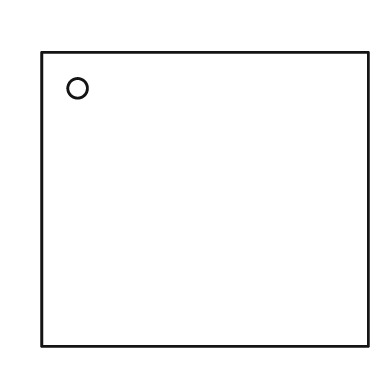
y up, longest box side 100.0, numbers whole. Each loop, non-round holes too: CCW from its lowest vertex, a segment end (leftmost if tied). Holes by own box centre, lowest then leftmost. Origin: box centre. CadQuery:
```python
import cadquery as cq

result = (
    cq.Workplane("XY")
    .moveTo(-50.0, -45.0)
    .lineTo(50.0, -45.0)
    .lineTo(50.0, 45.0)
    .lineTo(-50.0, 45.0)
    .close()
    .moveTo(-39.0, 34.0)
    .circle(3.0)
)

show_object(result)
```